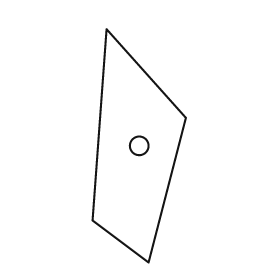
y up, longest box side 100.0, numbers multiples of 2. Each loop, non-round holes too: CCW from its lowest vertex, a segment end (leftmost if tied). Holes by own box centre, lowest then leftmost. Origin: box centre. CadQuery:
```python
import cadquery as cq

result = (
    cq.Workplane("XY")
    .moveTo(4.0, -50.0)
    .lineTo(20.0, 12.0)
    .lineTo(-14.0, 50.0)
    .lineTo(-20.0, -32.0)
    .close()
    .moveTo(0.0, 0.0)
    .circle(4.0)
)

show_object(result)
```